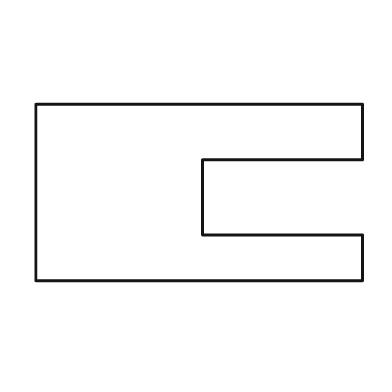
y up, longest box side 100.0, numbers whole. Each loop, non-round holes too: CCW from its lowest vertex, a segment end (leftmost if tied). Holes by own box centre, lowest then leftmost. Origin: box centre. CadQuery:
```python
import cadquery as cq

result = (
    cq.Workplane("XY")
    .moveTo(-50.0, -27.0)
    .lineTo(50.0, -27.0)
    .lineTo(50.0, -13.0)
    .lineTo(1.0, -13.0)
    .lineTo(1.0, 10.0)
    .lineTo(50.0, 10.0)
    .lineTo(50.0, 27.0)
    .lineTo(-50.0, 27.0)
    .close()
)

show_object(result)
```